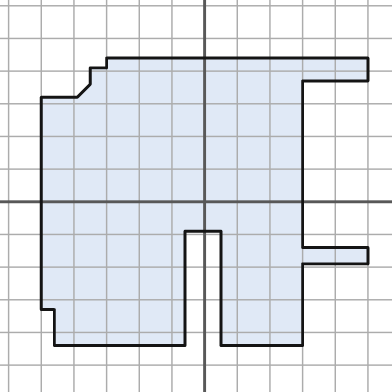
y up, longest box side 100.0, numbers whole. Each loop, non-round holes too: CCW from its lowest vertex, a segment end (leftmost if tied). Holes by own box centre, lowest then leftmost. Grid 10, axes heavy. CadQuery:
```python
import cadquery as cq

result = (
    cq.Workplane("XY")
    .moveTo(-46.0, -44.0)
    .lineTo(-6.0, -44.0)
    .lineTo(-6.0, -9.0)
    .lineTo(5.0, -9.0)
    .lineTo(5.0, -44.0)
    .lineTo(30.0, -44.0)
    .lineTo(30.0, -19.0)
    .lineTo(50.0, -19.0)
    .lineTo(50.0, -14.0)
    .lineTo(30.0, -14.0)
    .lineTo(30.0, 37.0)
    .lineTo(50.0, 37.0)
    .lineTo(50.0, 44.0)
    .lineTo(-30.0, 44.0)
    .lineTo(-30.0, 41.0)
    .lineTo(-35.0, 41.0)
    .lineTo(-35.0, 36.0)
    .lineTo(-39.0, 32.0)
    .lineTo(-50.0, 32.0)
    .lineTo(-50.0, -33.0)
    .lineTo(-46.0, -33.0)
    .close()
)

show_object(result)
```